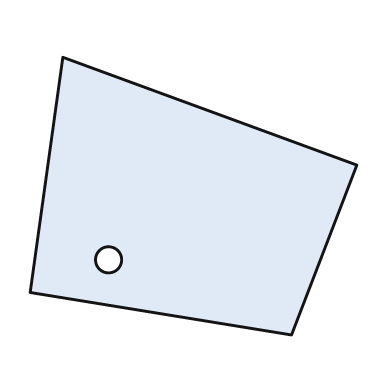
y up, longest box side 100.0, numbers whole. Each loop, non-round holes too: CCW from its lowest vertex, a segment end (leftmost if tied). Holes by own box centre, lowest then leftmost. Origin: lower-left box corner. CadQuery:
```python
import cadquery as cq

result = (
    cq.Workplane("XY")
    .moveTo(80.0, 0.0)
    .lineTo(100.0, 52.0)
    .lineTo(10.0, 85.0)
    .lineTo(0.0, 13.0)
    .close()
    .moveTo(24.0, 23.0)
    .circle(4.0)
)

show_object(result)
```